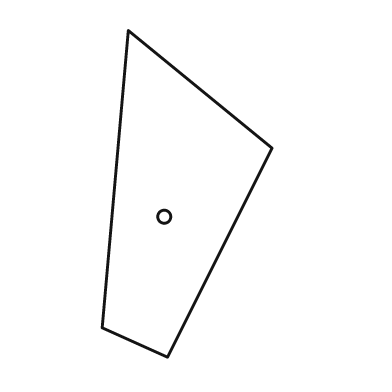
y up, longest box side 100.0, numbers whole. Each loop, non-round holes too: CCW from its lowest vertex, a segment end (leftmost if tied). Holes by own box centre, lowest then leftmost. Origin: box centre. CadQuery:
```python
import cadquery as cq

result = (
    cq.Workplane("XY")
    .moveTo(-6.0, -50.0)
    .lineTo(26.0, 14.0)
    .lineTo(-18.0, 50.0)
    .lineTo(-26.0, -41.0)
    .close()
    .moveTo(-7.0, -7.0)
    .circle(2.0)
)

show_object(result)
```